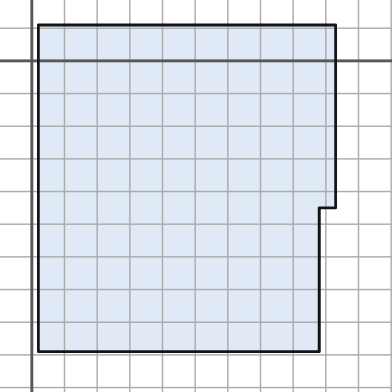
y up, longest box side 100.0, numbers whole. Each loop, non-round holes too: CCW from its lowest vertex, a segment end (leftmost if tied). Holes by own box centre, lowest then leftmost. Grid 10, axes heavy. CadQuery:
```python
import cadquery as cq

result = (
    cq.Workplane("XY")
    .moveTo(2.0, -89.0)
    .lineTo(88.0, -89.0)
    .lineTo(88.0, -45.0)
    .lineTo(93.0, -45.0)
    .lineTo(93.0, 11.0)
    .lineTo(2.0, 11.0)
    .close()
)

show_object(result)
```